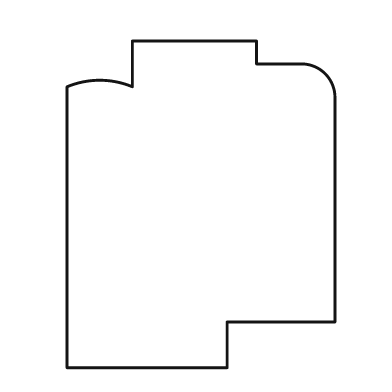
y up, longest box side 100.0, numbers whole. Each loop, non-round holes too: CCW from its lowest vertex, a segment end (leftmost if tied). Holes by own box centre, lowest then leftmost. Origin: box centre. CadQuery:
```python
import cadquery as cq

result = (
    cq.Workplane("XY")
    .moveTo(-41.0, -50.0)
    .lineTo(8.0, -50.0)
    .lineTo(8.0, -36.0)
    .lineTo(41.0, -36.0)
    .lineTo(41.0, 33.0)
    .threePointArc((38.0, 40.0), (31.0, 43.0))
    .lineTo(17.0, 43.0)
    .lineTo(17.0, 50.0)
    .lineTo(-21.0, 50.0)
    .lineTo(-21.0, 36.0)
    .threePointArc((-31.0, 38.0), (-41.0, 36.0))
    .close()
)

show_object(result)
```